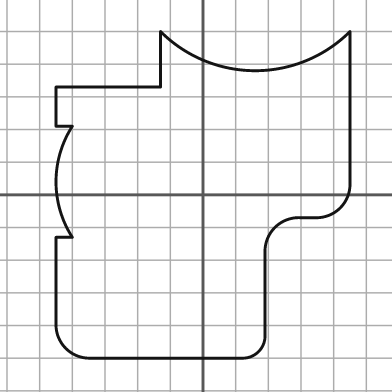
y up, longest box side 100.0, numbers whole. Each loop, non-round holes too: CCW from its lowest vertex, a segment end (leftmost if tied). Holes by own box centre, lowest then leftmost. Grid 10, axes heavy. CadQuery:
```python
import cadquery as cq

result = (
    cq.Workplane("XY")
    .moveTo(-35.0, -50.0)
    .lineTo(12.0, -50.0)
    .threePointArc((17.0, -48.0), (19.0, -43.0))
    .lineTo(19.0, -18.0)
    .threePointArc((22.0, -10.0), (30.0, -7.0))
    .lineTo(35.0, -7.0)
    .threePointArc((42.0, -4.0), (45.0, 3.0))
    .lineTo(45.0, 50.0)
    .threePointArc((16.0, 38.0), (-13.0, 50.0))
    .lineTo(-13.0, 33.0)
    .lineTo(-45.0, 33.0)
    .lineTo(-45.0, 21.0)
    .lineTo(-40.0, 21.0)
    .threePointArc((-45.0, 4.0), (-40.0, -13.0))
    .lineTo(-45.0, -13.0)
    .lineTo(-45.0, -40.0)
    .threePointArc((-42.0, -47.0), (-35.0, -50.0))
    .close()
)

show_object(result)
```